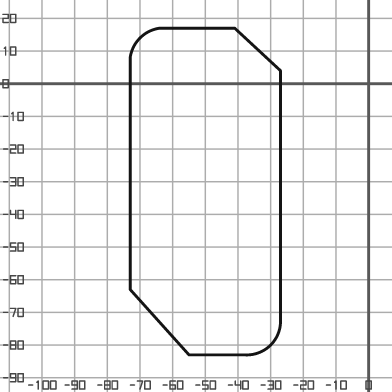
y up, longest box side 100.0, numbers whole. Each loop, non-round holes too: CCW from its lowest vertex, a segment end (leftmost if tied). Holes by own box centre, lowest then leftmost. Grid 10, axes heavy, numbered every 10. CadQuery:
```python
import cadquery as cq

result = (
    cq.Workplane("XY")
    .moveTo(-55.0, -83.0)
    .lineTo(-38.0, -83.0)
    .threePointArc((-30.0, -80.0), (-27.0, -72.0))
    .lineTo(-27.0, 4.0)
    .lineTo(-41.0, 17.0)
    .lineTo(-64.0, 17.0)
    .threePointArc((-70.0, 14.0), (-73.0, 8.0))
    .lineTo(-73.0, -63.0)
    .close()
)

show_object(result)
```